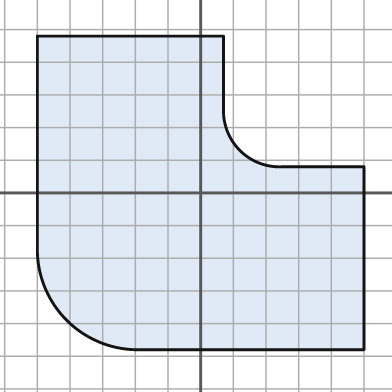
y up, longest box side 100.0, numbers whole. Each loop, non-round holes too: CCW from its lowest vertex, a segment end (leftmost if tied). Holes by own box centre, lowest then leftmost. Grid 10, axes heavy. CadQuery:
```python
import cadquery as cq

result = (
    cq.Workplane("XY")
    .moveTo(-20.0, -48.0)
    .lineTo(50.0, -48.0)
    .lineTo(50.0, 8.0)
    .lineTo(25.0, 8.0)
    .threePointArc((12.0, 13.0), (7.0, 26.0))
    .lineTo(7.0, 48.0)
    .lineTo(-50.0, 48.0)
    .lineTo(-50.0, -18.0)
    .threePointArc((-41.0, -39.0), (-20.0, -48.0))
    .close()
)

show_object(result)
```